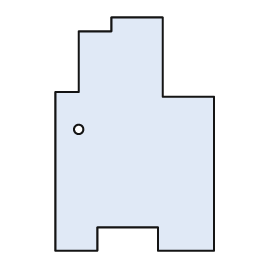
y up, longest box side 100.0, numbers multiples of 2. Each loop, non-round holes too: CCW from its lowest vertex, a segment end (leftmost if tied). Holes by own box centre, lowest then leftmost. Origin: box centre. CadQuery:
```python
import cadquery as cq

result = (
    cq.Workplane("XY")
    .moveTo(-34.0, -50.0)
    .lineTo(-16.0, -50.0)
    .lineTo(-16.0, -40.0)
    .lineTo(10.0, -40.0)
    .lineTo(10.0, -50.0)
    .lineTo(34.0, -50.0)
    .lineTo(34.0, 16.0)
    .lineTo(12.0, 16.0)
    .lineTo(12.0, 50.0)
    .lineTo(-10.0, 50.0)
    .lineTo(-10.0, 44.0)
    .lineTo(-24.0, 44.0)
    .lineTo(-24.0, 18.0)
    .lineTo(-34.0, 18.0)
    .close()
    .moveTo(-24.0, 2.0)
    .circle(2.0)
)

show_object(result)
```